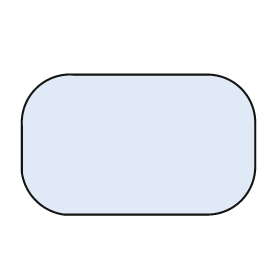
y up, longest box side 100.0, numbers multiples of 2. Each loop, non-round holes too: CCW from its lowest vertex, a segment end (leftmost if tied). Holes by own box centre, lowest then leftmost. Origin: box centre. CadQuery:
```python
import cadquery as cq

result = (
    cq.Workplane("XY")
    .moveTo(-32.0, -30.0)
    .lineTo(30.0, -30.0)
    .threePointArc((44.0, -24.0), (50.0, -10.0))
    .lineTo(50.0, 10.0)
    .threePointArc((44.0, 24.0), (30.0, 30.0))
    .lineTo(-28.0, 30.0)
    .threePointArc((-44.0, 24.0), (-50.0, 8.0))
    .lineTo(-50.0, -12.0)
    .threePointArc((-44.0, -24.0), (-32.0, -30.0))
    .close()
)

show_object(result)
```